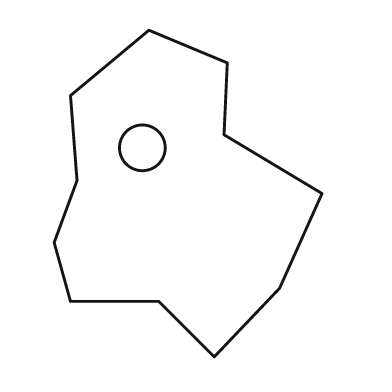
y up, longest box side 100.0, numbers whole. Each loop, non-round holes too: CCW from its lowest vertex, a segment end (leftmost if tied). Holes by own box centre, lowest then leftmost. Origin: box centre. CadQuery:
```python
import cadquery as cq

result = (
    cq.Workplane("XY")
    .moveTo(8.0, -50.0)
    .lineTo(28.0, -29.0)
    .lineTo(41.0, 0.0)
    .lineTo(11.0, 18.0)
    .lineTo(12.0, 40.0)
    .lineTo(-12.0, 50.0)
    .lineTo(-36.0, 30.0)
    .lineTo(-34.0, 4.0)
    .lineTo(-41.0, -15.0)
    .lineTo(-36.0, -33.0)
    .lineTo(-9.0, -33.0)
    .close()
    .moveTo(-14.0, 14.0)
    .circle(7.0)
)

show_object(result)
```